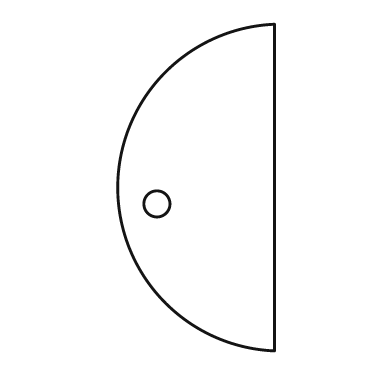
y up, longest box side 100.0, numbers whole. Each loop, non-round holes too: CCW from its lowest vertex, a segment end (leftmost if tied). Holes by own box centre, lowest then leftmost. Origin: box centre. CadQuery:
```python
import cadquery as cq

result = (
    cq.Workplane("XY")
    .moveTo(24.0, -50.0)
    .lineTo(24.0, 50.0)
    .threePointArc((-24.0, 0.0), (24.0, -50.0))
    .close()
    .moveTo(-12.0, -5.0)
    .circle(4.0)
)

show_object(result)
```